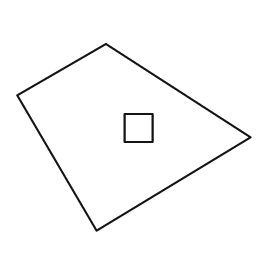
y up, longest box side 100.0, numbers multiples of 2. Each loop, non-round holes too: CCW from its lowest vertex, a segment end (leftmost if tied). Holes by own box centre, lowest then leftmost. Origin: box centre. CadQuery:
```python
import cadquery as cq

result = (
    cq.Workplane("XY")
    .moveTo(-16.0, -40.0)
    .lineTo(50.0, 0.0)
    .lineTo(-12.0, 40.0)
    .lineTo(-50.0, 18.0)
    .close()
    .moveTo(-4.0, -2.0)
    .lineTo(8.0, -2.0)
    .lineTo(8.0, 10.0)
    .lineTo(-4.0, 10.0)
    .close()
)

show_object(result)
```